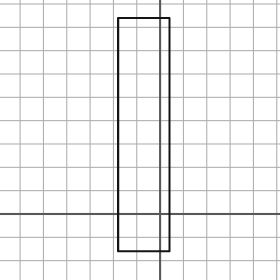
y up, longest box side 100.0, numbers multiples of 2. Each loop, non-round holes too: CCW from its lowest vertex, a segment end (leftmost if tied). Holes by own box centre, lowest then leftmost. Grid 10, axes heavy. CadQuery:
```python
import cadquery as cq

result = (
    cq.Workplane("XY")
    .moveTo(-18.0, -16.0)
    .lineTo(4.0, -16.0)
    .lineTo(4.0, 84.0)
    .lineTo(-18.0, 84.0)
    .close()
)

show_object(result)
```